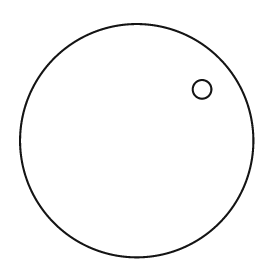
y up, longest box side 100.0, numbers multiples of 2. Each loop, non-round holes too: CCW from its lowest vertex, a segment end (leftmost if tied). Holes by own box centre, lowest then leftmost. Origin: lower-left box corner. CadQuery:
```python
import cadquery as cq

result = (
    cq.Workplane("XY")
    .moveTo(50.0, 50.0)
    .circle(50.0)
    .moveTo(78.0, 72.0)
    .circle(4.0)
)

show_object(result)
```